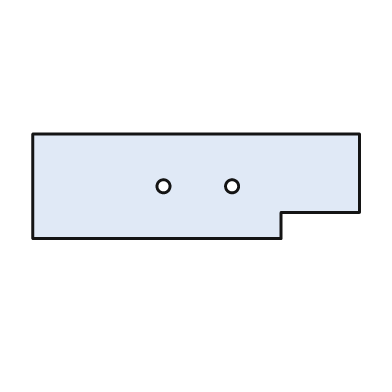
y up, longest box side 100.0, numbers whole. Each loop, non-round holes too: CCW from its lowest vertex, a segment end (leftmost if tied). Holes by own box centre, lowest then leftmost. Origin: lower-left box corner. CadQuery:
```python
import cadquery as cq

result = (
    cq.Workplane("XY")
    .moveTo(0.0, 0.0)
    .lineTo(76.0, 0.0)
    .lineTo(76.0, 8.0)
    .lineTo(100.0, 8.0)
    .lineTo(100.0, 32.0)
    .lineTo(0.0, 32.0)
    .close()
    .moveTo(40.0, 16.0)
    .circle(2.0)
    .moveTo(61.0, 16.0)
    .circle(2.0)
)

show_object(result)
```